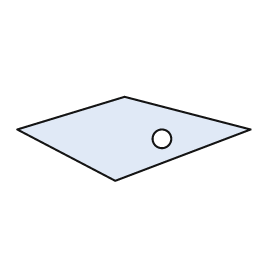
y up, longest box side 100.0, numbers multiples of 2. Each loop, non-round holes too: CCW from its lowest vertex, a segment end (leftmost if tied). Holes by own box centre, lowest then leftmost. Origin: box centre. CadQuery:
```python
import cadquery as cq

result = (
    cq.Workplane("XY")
    .moveTo(-8.0, -18.0)
    .lineTo(50.0, 4.0)
    .lineTo(-4.0, 18.0)
    .lineTo(-50.0, 4.0)
    .close()
    .moveTo(12.0, 0.0)
    .circle(4.0)
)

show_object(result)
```